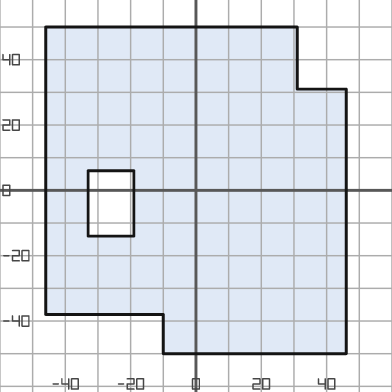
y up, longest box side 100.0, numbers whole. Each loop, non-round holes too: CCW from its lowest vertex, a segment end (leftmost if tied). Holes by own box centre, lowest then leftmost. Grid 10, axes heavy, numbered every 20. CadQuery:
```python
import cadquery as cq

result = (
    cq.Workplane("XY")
    .moveTo(-10.0, -50.0)
    .lineTo(46.0, -50.0)
    .lineTo(46.0, 31.0)
    .lineTo(31.0, 31.0)
    .lineTo(31.0, 50.0)
    .lineTo(-46.0, 50.0)
    .lineTo(-46.0, -38.0)
    .lineTo(-10.0, -38.0)
    .close()
    .moveTo(-33.0, -14.0)
    .lineTo(-19.0, -14.0)
    .lineTo(-19.0, 6.0)
    .lineTo(-33.0, 6.0)
    .close()
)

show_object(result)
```